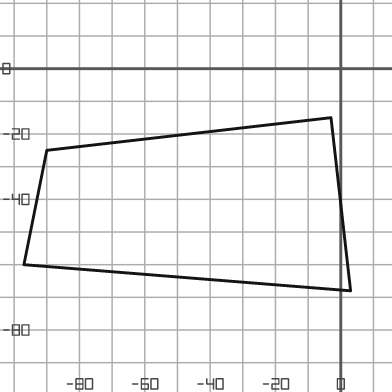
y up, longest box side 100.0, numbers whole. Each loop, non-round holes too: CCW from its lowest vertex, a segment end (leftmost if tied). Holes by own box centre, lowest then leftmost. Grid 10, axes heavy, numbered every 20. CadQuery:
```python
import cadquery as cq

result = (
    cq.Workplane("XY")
    .moveTo(3.0, -68.0)
    .lineTo(-3.0, -15.0)
    .lineTo(-90.0, -25.0)
    .lineTo(-97.0, -60.0)
    .close()
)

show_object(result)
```